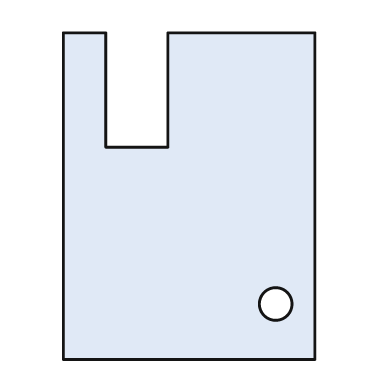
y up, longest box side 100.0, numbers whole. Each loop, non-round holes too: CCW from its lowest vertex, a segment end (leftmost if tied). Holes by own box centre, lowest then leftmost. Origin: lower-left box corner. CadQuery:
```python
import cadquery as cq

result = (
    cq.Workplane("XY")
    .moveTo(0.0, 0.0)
    .lineTo(77.0, 0.0)
    .lineTo(77.0, 100.0)
    .lineTo(32.0, 100.0)
    .lineTo(32.0, 65.0)
    .lineTo(13.0, 65.0)
    .lineTo(13.0, 100.0)
    .lineTo(0.0, 100.0)
    .close()
    .moveTo(65.0, 17.0)
    .circle(5.0)
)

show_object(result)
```